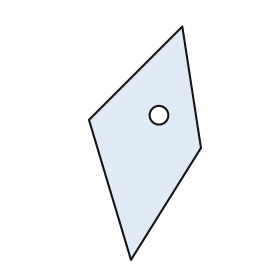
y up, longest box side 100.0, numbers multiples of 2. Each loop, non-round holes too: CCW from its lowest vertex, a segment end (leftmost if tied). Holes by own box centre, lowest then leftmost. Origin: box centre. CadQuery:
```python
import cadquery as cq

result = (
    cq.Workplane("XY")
    .moveTo(-6.0, -50.0)
    .lineTo(24.0, -2.0)
    .lineTo(16.0, 50.0)
    .lineTo(-24.0, 10.0)
    .close()
    .moveTo(6.0, 12.0)
    .circle(4.0)
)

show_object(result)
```